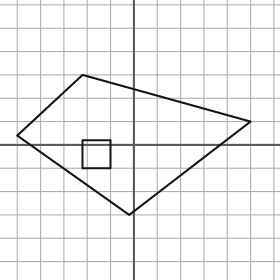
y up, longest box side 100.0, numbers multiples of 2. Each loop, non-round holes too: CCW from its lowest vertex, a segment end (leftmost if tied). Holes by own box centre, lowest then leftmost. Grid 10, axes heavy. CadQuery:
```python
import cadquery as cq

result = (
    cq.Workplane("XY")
    .moveTo(-2.0, -30.0)
    .lineTo(50.0, 10.0)
    .lineTo(-22.0, 30.0)
    .lineTo(-50.0, 4.0)
    .close()
    .moveTo(-22.0, -10.0)
    .lineTo(-10.0, -10.0)
    .lineTo(-10.0, 2.0)
    .lineTo(-22.0, 2.0)
    .close()
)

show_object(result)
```